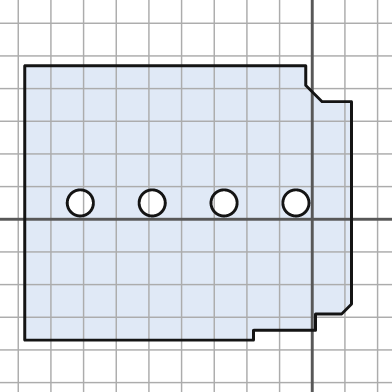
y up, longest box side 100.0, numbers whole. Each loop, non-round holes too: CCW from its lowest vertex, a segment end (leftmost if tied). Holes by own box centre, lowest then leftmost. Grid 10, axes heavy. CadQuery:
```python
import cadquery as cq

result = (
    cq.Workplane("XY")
    .moveTo(-88.0, -37.0)
    .lineTo(-18.0, -37.0)
    .lineTo(-18.0, -34.0)
    .lineTo(1.0, -34.0)
    .lineTo(1.0, -29.0)
    .lineTo(9.0, -29.0)
    .lineTo(12.0, -26.0)
    .lineTo(12.0, 36.0)
    .lineTo(3.0, 36.0)
    .lineTo(-2.0, 41.0)
    .lineTo(-2.0, 47.0)
    .lineTo(-88.0, 47.0)
    .close()
    .moveTo(-71.0, 5.0)
    .circle(4.0)
    .moveTo(-49.0, 5.0)
    .circle(4.0)
    .moveTo(-27.0, 5.0)
    .circle(4.0)
    .moveTo(-5.0, 5.0)
    .circle(4.0)
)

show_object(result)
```